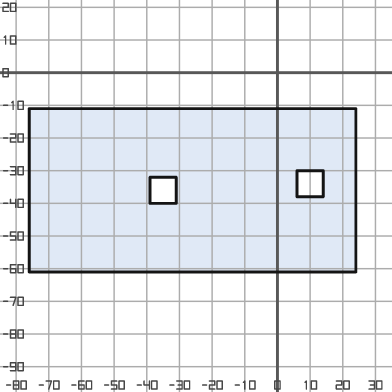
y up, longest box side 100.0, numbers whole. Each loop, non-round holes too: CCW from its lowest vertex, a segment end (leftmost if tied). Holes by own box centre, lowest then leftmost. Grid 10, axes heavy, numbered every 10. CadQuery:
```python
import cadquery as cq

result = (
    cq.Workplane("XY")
    .moveTo(-76.0, -61.0)
    .lineTo(24.0, -61.0)
    .lineTo(24.0, -11.0)
    .lineTo(-76.0, -11.0)
    .close()
    .moveTo(-39.0, -40.0)
    .lineTo(-31.0, -40.0)
    .lineTo(-31.0, -32.0)
    .lineTo(-39.0, -32.0)
    .close()
    .moveTo(6.0, -38.0)
    .lineTo(14.0, -38.0)
    .lineTo(14.0, -30.0)
    .lineTo(6.0, -30.0)
    .close()
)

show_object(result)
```